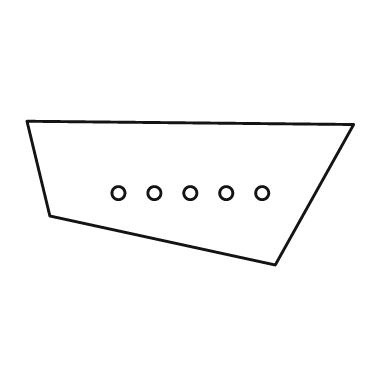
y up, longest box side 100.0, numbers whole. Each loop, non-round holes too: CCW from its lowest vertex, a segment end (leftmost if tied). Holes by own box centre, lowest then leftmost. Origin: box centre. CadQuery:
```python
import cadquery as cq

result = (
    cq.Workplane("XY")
    .moveTo(26.0, -22.0)
    .lineTo(50.0, 21.0)
    .lineTo(-50.0, 22.0)
    .lineTo(-43.0, -7.0)
    .close()
    .moveTo(-22.0, 0.0)
    .circle(2.0)
    .moveTo(-11.0, 0.0)
    .circle(2.0)
    .moveTo(0.0, 0.0)
    .circle(2.0)
    .moveTo(11.0, 0.0)
    .circle(2.0)
    .moveTo(22.0, 0.0)
    .circle(2.0)
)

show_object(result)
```